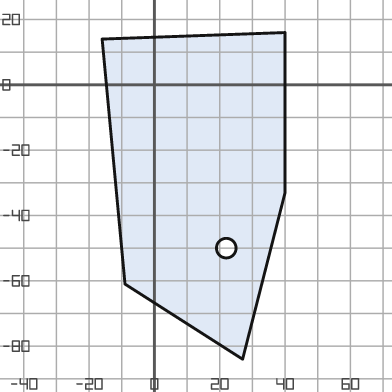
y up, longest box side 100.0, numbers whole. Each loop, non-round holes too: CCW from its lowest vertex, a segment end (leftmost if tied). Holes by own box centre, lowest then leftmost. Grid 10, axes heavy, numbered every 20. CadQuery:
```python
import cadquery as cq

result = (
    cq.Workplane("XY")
    .moveTo(27.0, -84.0)
    .lineTo(40.0, -33.0)
    .lineTo(40.0, 16.0)
    .lineTo(-16.0, 14.0)
    .lineTo(-9.0, -61.0)
    .close()
    .moveTo(22.0, -50.0)
    .circle(3.0)
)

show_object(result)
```